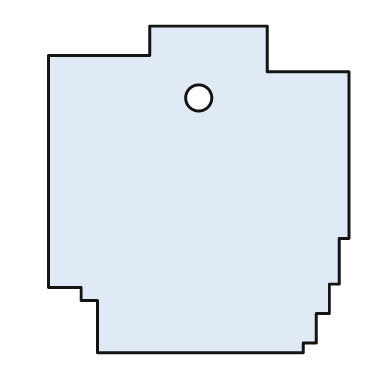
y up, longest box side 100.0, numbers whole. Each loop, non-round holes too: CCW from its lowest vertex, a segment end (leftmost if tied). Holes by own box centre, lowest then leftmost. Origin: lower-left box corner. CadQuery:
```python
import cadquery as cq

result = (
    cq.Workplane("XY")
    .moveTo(15.0, 0.0)
    .lineTo(78.0, 0.0)
    .lineTo(78.0, 3.0)
    .lineTo(82.0, 3.0)
    .lineTo(82.0, 12.0)
    .lineTo(86.0, 12.0)
    .lineTo(86.0, 21.0)
    .lineTo(89.0, 21.0)
    .lineTo(89.0, 35.0)
    .lineTo(92.0, 35.0)
    .lineTo(92.0, 86.0)
    .lineTo(67.0, 86.0)
    .lineTo(67.0, 100.0)
    .lineTo(31.0, 100.0)
    .lineTo(31.0, 91.0)
    .lineTo(0.0, 91.0)
    .lineTo(0.0, 20.0)
    .lineTo(10.0, 20.0)
    .lineTo(10.0, 16.0)
    .lineTo(15.0, 16.0)
    .close()
    .moveTo(46.0, 78.0)
    .circle(4.0)
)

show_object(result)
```